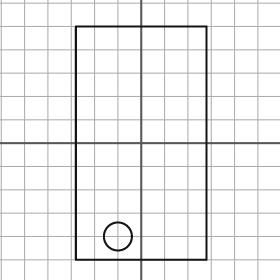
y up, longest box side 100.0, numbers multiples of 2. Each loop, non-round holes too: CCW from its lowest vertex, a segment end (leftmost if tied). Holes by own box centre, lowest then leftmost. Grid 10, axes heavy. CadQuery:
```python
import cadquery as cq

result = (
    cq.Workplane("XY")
    .moveTo(-28.0, -50.0)
    .lineTo(28.0, -50.0)
    .lineTo(28.0, 50.0)
    .lineTo(-28.0, 50.0)
    .close()
    .moveTo(-10.0, -40.0)
    .circle(6.0)
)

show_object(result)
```